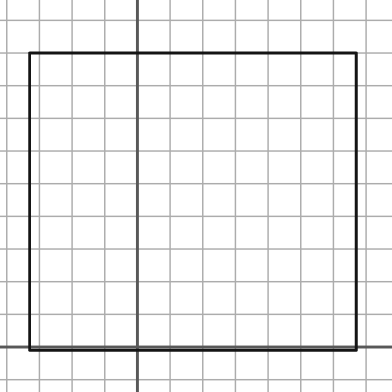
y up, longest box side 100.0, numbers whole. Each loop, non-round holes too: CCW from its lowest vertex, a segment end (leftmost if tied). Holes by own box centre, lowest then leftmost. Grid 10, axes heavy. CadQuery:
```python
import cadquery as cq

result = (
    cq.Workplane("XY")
    .moveTo(-33.0, -1.0)
    .lineTo(67.0, -1.0)
    .lineTo(67.0, 90.0)
    .lineTo(-33.0, 90.0)
    .close()
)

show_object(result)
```